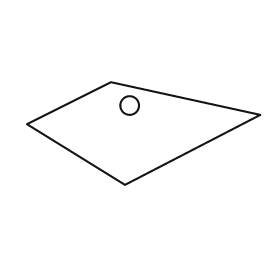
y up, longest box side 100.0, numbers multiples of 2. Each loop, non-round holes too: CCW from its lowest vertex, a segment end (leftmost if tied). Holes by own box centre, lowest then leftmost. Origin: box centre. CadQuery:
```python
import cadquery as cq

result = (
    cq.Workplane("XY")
    .moveTo(-8.0, -22.0)
    .lineTo(50.0, 8.0)
    .lineTo(-14.0, 22.0)
    .lineTo(-50.0, 4.0)
    .close()
    .moveTo(-6.0, 12.0)
    .circle(4.0)
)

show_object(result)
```